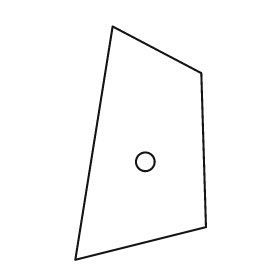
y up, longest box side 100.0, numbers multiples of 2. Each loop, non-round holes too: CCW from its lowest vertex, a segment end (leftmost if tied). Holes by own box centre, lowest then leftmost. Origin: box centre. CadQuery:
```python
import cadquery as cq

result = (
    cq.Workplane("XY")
    .moveTo(-28.0, -50.0)
    .lineTo(28.0, -36.0)
    .lineTo(26.0, 30.0)
    .lineTo(-12.0, 50.0)
    .close()
    .moveTo(2.0, -8.0)
    .circle(4.0)
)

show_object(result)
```